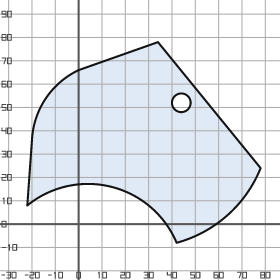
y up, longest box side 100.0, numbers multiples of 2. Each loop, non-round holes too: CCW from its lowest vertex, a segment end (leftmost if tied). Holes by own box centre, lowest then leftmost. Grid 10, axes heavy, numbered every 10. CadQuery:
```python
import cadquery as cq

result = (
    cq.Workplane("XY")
    .moveTo(42.0, -8.0)
    .threePointArc((64.0, 4.0), (78.0, 24.0))
    .lineTo(34.0, 78.0)
    .lineTo(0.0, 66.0)
    .threePointArc((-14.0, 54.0), (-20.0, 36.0))
    .lineTo(-22.0, 8.0)
    .threePointArc((14.0, 16.0), (42.0, -8.0))
    .close()
    .moveTo(44.0, 52.0)
    .circle(4.0)
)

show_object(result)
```